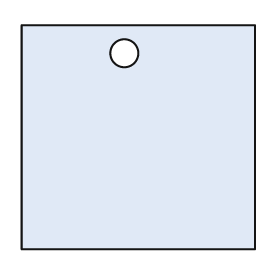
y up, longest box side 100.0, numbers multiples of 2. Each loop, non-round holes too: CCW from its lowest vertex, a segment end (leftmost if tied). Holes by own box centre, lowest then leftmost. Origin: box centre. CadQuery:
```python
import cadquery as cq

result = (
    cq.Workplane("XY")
    .moveTo(-50.0, -48.0)
    .lineTo(50.0, -48.0)
    .lineTo(50.0, 48.0)
    .lineTo(-50.0, 48.0)
    .close()
    .moveTo(-6.0, 36.0)
    .circle(6.0)
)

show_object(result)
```